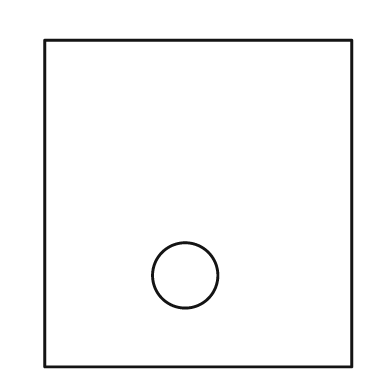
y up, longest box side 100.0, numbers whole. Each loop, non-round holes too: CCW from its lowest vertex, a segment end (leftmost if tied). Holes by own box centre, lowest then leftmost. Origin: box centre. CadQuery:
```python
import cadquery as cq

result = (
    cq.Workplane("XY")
    .moveTo(-47.0, -50.0)
    .lineTo(47.0, -50.0)
    .lineTo(47.0, 50.0)
    .lineTo(-47.0, 50.0)
    .close()
    .moveTo(-4.0, -22.0)
    .circle(10.0)
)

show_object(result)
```